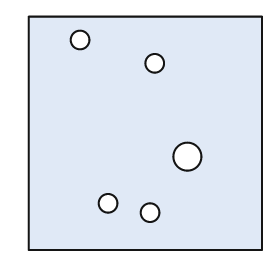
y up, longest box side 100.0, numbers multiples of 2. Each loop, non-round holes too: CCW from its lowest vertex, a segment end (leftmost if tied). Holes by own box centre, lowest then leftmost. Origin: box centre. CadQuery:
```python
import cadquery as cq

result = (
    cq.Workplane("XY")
    .moveTo(-50.0, -50.0)
    .lineTo(50.0, -50.0)
    .lineTo(50.0, 50.0)
    .lineTo(-50.0, 50.0)
    .close()
    .moveTo(2.0, -34.0)
    .circle(4.0)
    .moveTo(-16.0, -30.0)
    .circle(4.0)
    .moveTo(18.0, -10.0)
    .circle(6.0)
    .moveTo(4.0, 30.0)
    .circle(4.0)
    .moveTo(-28.0, 40.0)
    .circle(4.0)
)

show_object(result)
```